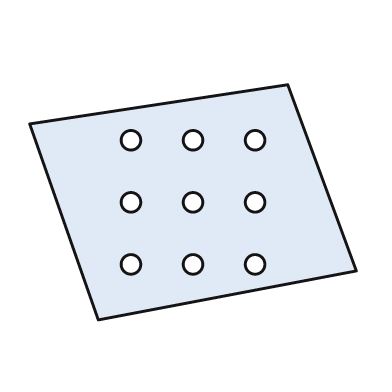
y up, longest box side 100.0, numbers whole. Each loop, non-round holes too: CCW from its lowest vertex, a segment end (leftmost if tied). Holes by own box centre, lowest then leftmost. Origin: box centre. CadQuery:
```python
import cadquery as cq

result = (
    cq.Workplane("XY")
    .moveTo(-29.0, -36.0)
    .lineTo(50.0, -21.0)
    .lineTo(29.0, 36.0)
    .lineTo(-50.0, 24.0)
    .close()
    .moveTo(-19.0, -19.0)
    .circle(3.0)
    .moveTo(0.0, -19.0)
    .circle(3.0)
    .moveTo(19.0, -19.0)
    .circle(3.0)
    .moveTo(-19.0, 0.0)
    .circle(3.0)
    .moveTo(0.0, 0.0)
    .circle(3.0)
    .moveTo(19.0, 0.0)
    .circle(3.0)
    .moveTo(-19.0, 19.0)
    .circle(3.0)
    .moveTo(0.0, 19.0)
    .circle(3.0)
    .moveTo(19.0, 19.0)
    .circle(3.0)
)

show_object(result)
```